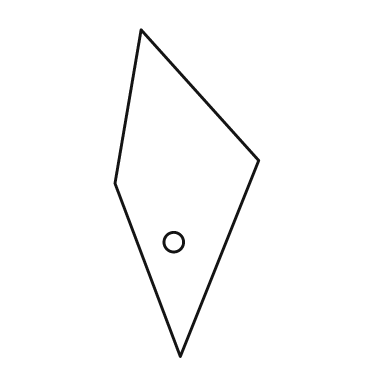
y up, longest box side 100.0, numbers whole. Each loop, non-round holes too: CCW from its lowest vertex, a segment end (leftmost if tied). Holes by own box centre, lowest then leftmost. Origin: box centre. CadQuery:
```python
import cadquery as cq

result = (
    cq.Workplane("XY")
    .moveTo(-2.0, -50.0)
    .lineTo(22.0, 10.0)
    .lineTo(-14.0, 50.0)
    .lineTo(-22.0, 3.0)
    .close()
    .moveTo(-4.0, -15.0)
    .circle(3.0)
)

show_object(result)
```